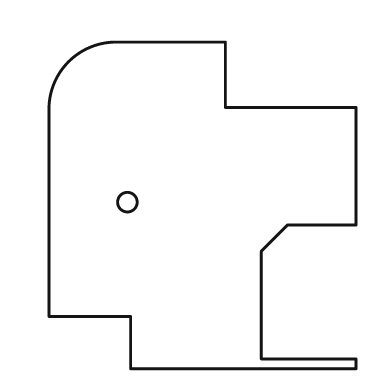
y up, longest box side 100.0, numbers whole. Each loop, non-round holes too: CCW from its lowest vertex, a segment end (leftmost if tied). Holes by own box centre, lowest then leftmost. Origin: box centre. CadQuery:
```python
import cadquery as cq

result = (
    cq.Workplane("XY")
    .moveTo(-22.0, -50.0)
    .lineTo(47.0, -50.0)
    .lineTo(47.0, -47.0)
    .lineTo(18.0, -47.0)
    .lineTo(18.0, -14.0)
    .lineTo(26.0, -6.0)
    .lineTo(47.0, -6.0)
    .lineTo(47.0, 30.0)
    .lineTo(7.0, 30.0)
    .lineTo(7.0, 50.0)
    .lineTo(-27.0, 50.0)
    .threePointArc((-41.0, 44.0), (-47.0, 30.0))
    .lineTo(-47.0, -34.0)
    .lineTo(-22.0, -34.0)
    .close()
    .moveTo(-23.0, 1.0)
    .circle(3.0)
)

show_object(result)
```